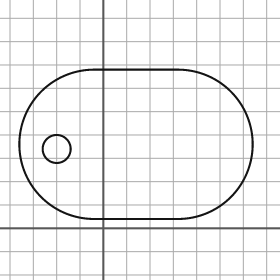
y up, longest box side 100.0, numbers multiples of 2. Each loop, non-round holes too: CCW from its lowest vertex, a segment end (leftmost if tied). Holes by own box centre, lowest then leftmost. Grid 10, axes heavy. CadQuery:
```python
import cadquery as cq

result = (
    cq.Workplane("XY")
    .moveTo(-4.0, 4.0)
    .lineTo(32.0, 4.0)
    .threePointArc((64.0, 36.0), (32.0, 68.0))
    .lineTo(-4.0, 68.0)
    .threePointArc((-36.0, 36.0), (-4.0, 4.0))
    .close()
    .moveTo(-20.0, 34.0)
    .circle(6.0)
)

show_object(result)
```